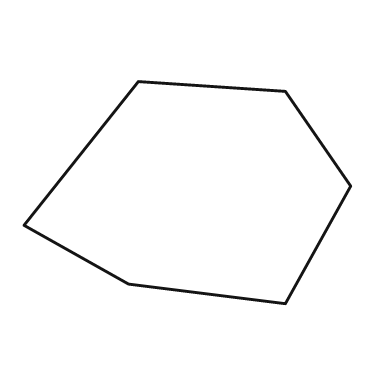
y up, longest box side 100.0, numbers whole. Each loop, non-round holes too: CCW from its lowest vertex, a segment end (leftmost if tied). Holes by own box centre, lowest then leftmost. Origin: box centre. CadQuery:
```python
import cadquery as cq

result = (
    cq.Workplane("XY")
    .moveTo(30.0, -34.0)
    .lineTo(50.0, 2.0)
    .lineTo(30.0, 31.0)
    .lineTo(-15.0, 34.0)
    .lineTo(-50.0, -10.0)
    .lineTo(-18.0, -28.0)
    .close()
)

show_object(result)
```